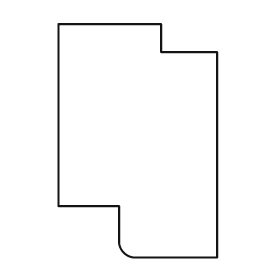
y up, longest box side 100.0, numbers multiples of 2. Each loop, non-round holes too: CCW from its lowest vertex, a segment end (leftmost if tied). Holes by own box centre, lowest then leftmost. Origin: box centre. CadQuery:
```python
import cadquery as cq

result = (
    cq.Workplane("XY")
    .moveTo(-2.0, -50.0)
    .lineTo(34.0, -50.0)
    .lineTo(34.0, 38.0)
    .lineTo(10.0, 38.0)
    .lineTo(10.0, 50.0)
    .lineTo(-34.0, 50.0)
    .lineTo(-34.0, -28.0)
    .lineTo(-8.0, -28.0)
    .lineTo(-8.0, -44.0)
    .threePointArc((-6.0, -48.0), (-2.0, -50.0))
    .close()
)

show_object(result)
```